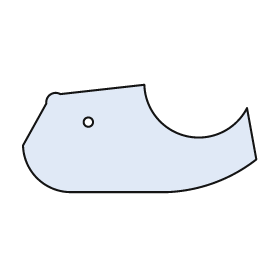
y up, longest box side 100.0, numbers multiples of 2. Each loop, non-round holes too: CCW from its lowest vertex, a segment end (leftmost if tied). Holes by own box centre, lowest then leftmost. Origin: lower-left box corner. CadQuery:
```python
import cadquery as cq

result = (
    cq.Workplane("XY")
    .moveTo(20.0, 0.0)
    .lineTo(62.0, 0.0)
    .threePointArc((82.0, 4.0), (100.0, 14.0))
    .lineTo(96.0, 36.0)
    .threePointArc((70.0, 24.0), (52.0, 46.0))
    .lineTo(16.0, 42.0)
    .threePointArc((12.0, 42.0), (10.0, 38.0))
    .lineTo(0.0, 20.0)
    .threePointArc((6.0, 6.0), (20.0, 0.0))
    .close()
    .moveTo(28.0, 30.0)
    .circle(2.0)
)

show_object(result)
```